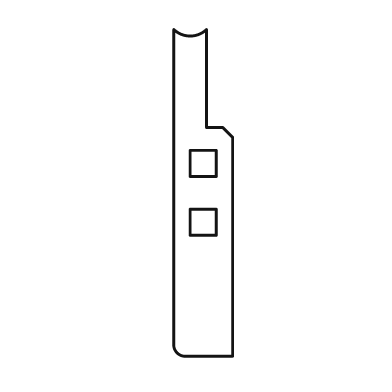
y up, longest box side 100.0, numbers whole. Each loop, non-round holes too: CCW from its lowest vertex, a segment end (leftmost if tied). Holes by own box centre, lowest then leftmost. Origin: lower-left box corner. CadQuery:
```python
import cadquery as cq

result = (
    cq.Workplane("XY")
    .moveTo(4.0, 0.0)
    .lineTo(18.0, 0.0)
    .lineTo(18.0, 67.0)
    .lineTo(15.0, 70.0)
    .lineTo(10.0, 70.0)
    .lineTo(10.0, 100.0)
    .threePointArc((5.0, 98.0), (0.0, 100.0))
    .lineTo(0.0, 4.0)
    .threePointArc((1.0, 1.0), (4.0, 0.0))
    .close()
    .moveTo(5.0, 37.0)
    .lineTo(13.0, 37.0)
    .lineTo(13.0, 45.0)
    .lineTo(5.0, 45.0)
    .close()
    .moveTo(5.0, 55.0)
    .lineTo(13.0, 55.0)
    .lineTo(13.0, 63.0)
    .lineTo(5.0, 63.0)
    .close()
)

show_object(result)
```